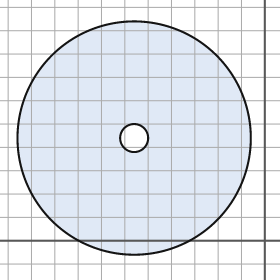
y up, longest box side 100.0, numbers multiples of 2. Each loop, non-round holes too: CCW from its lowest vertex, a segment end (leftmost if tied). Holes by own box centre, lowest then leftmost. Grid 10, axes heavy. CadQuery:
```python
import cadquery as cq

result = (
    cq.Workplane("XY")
    .moveTo(-56.0, 44.0)
    .circle(50.0)
    .moveTo(-56.0, 44.0)
    .circle(6.0)
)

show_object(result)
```